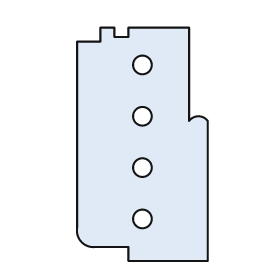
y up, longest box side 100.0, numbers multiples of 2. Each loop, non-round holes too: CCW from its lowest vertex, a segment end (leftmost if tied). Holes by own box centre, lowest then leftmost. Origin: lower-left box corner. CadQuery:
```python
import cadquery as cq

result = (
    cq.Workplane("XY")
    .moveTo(22.0, 0.0)
    .lineTo(56.0, 0.0)
    .lineTo(56.0, 60.0)
    .threePointArc((52.0, 62.0), (48.0, 60.0))
    .lineTo(48.0, 100.0)
    .lineTo(22.0, 100.0)
    .lineTo(22.0, 96.0)
    .lineTo(16.0, 96.0)
    .lineTo(16.0, 100.0)
    .lineTo(10.0, 100.0)
    .lineTo(10.0, 94.0)
    .lineTo(0.0, 94.0)
    .lineTo(0.0, 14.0)
    .threePointArc((2.0, 8.0), (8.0, 6.0))
    .lineTo(22.0, 6.0)
    .close()
    .moveTo(28.0, 18.0)
    .circle(4.0)
    .moveTo(28.0, 40.0)
    .circle(4.0)
    .moveTo(28.0, 62.0)
    .circle(4.0)
    .moveTo(28.0, 84.0)
    .circle(4.0)
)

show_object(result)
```